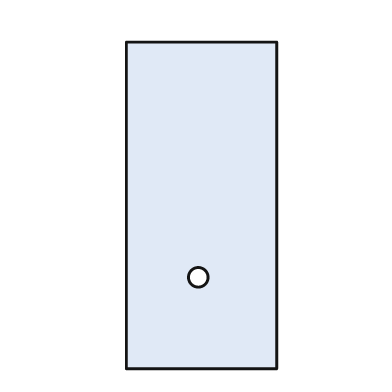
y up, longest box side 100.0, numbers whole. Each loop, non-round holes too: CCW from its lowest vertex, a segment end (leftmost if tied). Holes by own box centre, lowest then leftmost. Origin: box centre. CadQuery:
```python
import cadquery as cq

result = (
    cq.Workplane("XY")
    .moveTo(-23.0, -50.0)
    .lineTo(23.0, -50.0)
    .lineTo(23.0, 50.0)
    .lineTo(-23.0, 50.0)
    .close()
    .moveTo(-1.0, -22.0)
    .circle(3.0)
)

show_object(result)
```